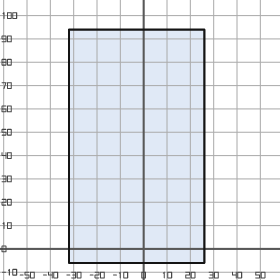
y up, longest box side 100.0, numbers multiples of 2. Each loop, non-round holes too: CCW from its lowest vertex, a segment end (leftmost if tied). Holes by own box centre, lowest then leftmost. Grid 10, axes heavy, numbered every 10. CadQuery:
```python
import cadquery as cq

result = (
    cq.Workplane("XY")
    .moveTo(-32.0, -6.0)
    .lineTo(26.0, -6.0)
    .lineTo(26.0, 94.0)
    .lineTo(-32.0, 94.0)
    .close()
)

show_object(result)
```